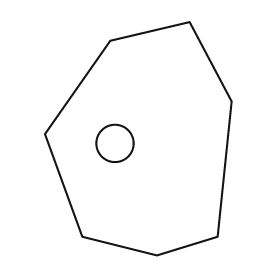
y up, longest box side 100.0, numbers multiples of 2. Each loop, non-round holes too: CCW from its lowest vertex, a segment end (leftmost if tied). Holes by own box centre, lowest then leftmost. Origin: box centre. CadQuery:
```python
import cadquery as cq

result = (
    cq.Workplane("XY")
    .moveTo(8.0, -50.0)
    .lineTo(34.0, -42.0)
    .lineTo(40.0, 16.0)
    .lineTo(22.0, 50.0)
    .lineTo(-12.0, 42.0)
    .lineTo(-40.0, 2.0)
    .lineTo(-24.0, -42.0)
    .close()
    .moveTo(-10.0, -2.0)
    .circle(8.0)
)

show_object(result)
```